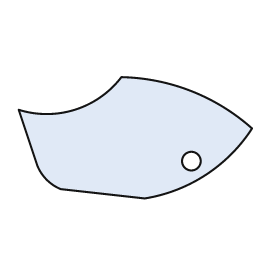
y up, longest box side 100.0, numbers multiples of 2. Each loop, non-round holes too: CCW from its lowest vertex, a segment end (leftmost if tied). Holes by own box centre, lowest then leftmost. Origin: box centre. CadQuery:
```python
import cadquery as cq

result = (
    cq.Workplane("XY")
    .moveTo(4.0, -26.0)
    .threePointArc((30.0, -16.0), (50.0, 4.0))
    .threePointArc((24.0, 20.0), (-6.0, 26.0))
    .threePointArc((-26.0, 12.0), (-50.0, 12.0))
    .lineTo(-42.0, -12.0)
    .threePointArc((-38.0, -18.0), (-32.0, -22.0))
    .close()
    .moveTo(24.0, -10.0)
    .circle(4.0)
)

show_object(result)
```